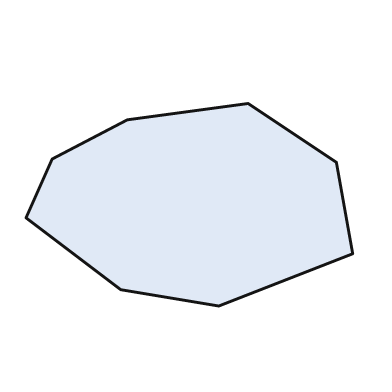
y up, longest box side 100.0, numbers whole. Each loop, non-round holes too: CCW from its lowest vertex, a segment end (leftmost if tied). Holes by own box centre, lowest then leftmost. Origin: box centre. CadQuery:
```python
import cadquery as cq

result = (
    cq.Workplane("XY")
    .moveTo(9.0, -31.0)
    .lineTo(50.0, -15.0)
    .lineTo(45.0, 13.0)
    .lineTo(18.0, 31.0)
    .lineTo(-19.0, 26.0)
    .lineTo(-42.0, 14.0)
    .lineTo(-50.0, -4.0)
    .lineTo(-21.0, -26.0)
    .close()
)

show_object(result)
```